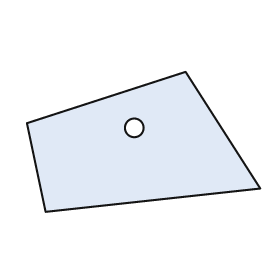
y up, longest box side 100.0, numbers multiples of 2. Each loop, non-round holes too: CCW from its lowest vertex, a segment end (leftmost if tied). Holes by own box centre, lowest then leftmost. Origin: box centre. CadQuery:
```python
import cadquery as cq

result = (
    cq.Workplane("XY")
    .moveTo(-42.0, -30.0)
    .lineTo(50.0, -20.0)
    .lineTo(18.0, 30.0)
    .lineTo(-50.0, 8.0)
    .close()
    .moveTo(-4.0, 6.0)
    .circle(4.0)
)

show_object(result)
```